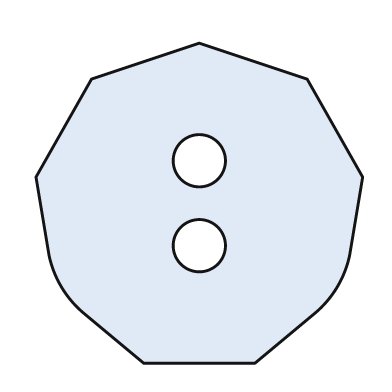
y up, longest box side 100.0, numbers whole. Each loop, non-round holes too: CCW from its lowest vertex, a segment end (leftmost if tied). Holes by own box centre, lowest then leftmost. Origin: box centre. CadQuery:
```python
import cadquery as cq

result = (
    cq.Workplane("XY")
    .moveTo(-17.0, -49.0)
    .lineTo(17.0, -49.0)
    .lineTo(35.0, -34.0)
    .threePointArc((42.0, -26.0), (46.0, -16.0))
    .lineTo(50.0, 8.0)
    .lineTo(33.0, 38.0)
    .lineTo(0.0, 49.0)
    .lineTo(-33.0, 38.0)
    .lineTo(-50.0, 8.0)
    .lineTo(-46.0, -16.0)
    .threePointArc((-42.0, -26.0), (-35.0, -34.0))
    .close()
    .moveTo(0.0, -13.0)
    .circle(8.0)
    .moveTo(0.0, 13.0)
    .circle(8.0)
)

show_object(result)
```